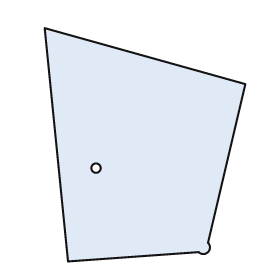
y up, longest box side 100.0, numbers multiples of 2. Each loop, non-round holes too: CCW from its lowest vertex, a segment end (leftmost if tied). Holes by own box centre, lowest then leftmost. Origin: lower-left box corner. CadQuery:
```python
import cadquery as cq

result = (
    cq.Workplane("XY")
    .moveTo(10.0, 0.0)
    .lineTo(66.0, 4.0)
    .threePointArc((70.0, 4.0), (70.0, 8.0))
    .lineTo(86.0, 76.0)
    .lineTo(0.0, 100.0)
    .close()
    .moveTo(22.0, 40.0)
    .circle(2.0)
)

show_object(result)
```